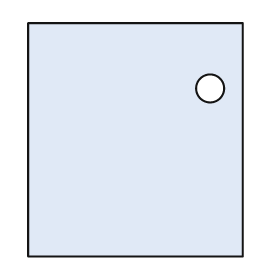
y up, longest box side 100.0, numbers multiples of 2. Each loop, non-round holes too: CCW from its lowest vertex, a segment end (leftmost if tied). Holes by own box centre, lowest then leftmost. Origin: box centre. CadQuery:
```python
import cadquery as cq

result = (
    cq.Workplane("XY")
    .moveTo(-46.0, -50.0)
    .lineTo(46.0, -50.0)
    .lineTo(46.0, 50.0)
    .lineTo(-46.0, 50.0)
    .close()
    .moveTo(32.0, 22.0)
    .circle(6.0)
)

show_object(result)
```